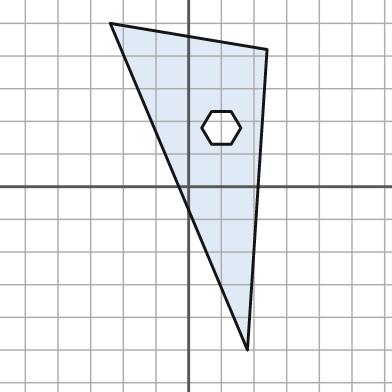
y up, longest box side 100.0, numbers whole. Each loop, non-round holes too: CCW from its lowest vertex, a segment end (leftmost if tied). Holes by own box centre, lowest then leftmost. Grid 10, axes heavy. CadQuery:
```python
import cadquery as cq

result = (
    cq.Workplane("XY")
    .moveTo(18.0, -50.0)
    .lineTo(24.0, 42.0)
    .lineTo(-24.0, 50.0)
    .close()
    .moveTo(7.0, 13.0)
    .lineTo(13.0, 13.0)
    .lineTo(16.0, 18.0)
    .lineTo(13.0, 23.0)
    .lineTo(7.0, 23.0)
    .lineTo(4.0, 18.0)
    .close()
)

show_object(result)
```